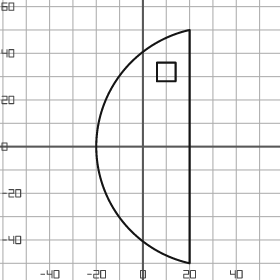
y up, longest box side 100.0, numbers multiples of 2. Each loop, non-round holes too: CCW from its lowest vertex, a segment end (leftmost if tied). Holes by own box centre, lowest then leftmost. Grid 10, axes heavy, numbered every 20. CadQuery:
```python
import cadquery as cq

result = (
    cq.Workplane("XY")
    .moveTo(20.0, -50.0)
    .lineTo(20.0, 50.0)
    .threePointArc((-20.0, 0.0), (20.0, -50.0))
    .close()
    .moveTo(6.0, 28.0)
    .lineTo(14.0, 28.0)
    .lineTo(14.0, 36.0)
    .lineTo(6.0, 36.0)
    .close()
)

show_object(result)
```